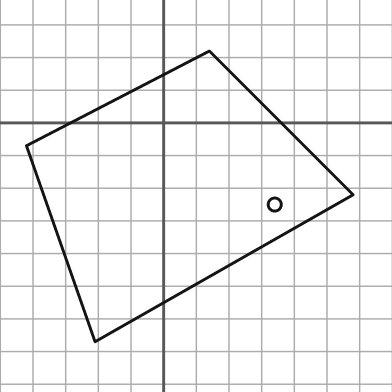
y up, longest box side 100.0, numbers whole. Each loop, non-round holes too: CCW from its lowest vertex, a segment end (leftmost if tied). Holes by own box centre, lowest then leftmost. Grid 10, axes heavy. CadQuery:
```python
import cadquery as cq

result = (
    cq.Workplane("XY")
    .moveTo(-21.0, -67.0)
    .lineTo(58.0, -22.0)
    .lineTo(14.0, 22.0)
    .lineTo(-42.0, -7.0)
    .close()
    .moveTo(34.0, -25.0)
    .circle(2.0)
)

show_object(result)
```